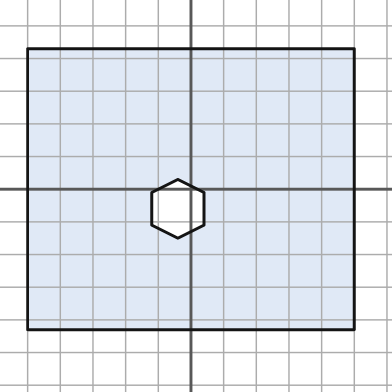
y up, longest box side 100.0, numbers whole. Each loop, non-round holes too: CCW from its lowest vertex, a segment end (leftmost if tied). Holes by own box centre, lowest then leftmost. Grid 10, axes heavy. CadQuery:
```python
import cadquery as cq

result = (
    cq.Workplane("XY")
    .moveTo(-50.0, -43.0)
    .lineTo(50.0, -43.0)
    .lineTo(50.0, 43.0)
    .lineTo(-50.0, 43.0)
    .close()
    .moveTo(-4.0, -15.0)
    .lineTo(4.0, -11.0)
    .lineTo(4.0, -1.0)
    .lineTo(-4.0, 3.0)
    .lineTo(-12.0, -1.0)
    .lineTo(-12.0, -11.0)
    .close()
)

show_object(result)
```